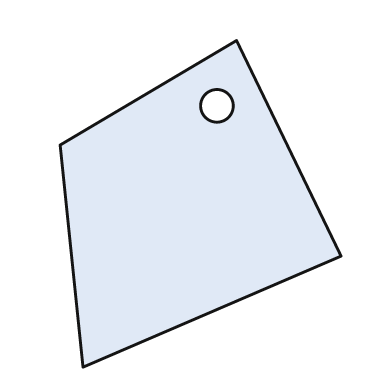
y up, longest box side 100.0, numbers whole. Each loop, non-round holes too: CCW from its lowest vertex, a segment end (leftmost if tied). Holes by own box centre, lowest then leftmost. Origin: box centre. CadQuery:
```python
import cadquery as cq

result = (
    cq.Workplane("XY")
    .moveTo(-36.0, -50.0)
    .lineTo(43.0, -16.0)
    .lineTo(11.0, 50.0)
    .lineTo(-43.0, 18.0)
    .close()
    .moveTo(5.0, 30.0)
    .circle(5.0)
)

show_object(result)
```